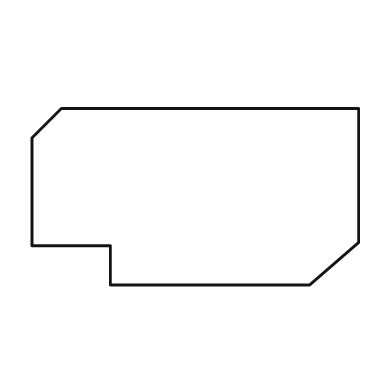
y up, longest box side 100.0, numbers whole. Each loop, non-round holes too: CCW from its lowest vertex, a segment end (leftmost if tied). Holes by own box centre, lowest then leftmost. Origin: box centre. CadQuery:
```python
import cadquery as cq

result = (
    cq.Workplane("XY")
    .moveTo(-26.0, -27.0)
    .lineTo(35.0, -27.0)
    .lineTo(50.0, -14.0)
    .lineTo(50.0, 27.0)
    .lineTo(-41.0, 27.0)
    .lineTo(-50.0, 18.0)
    .lineTo(-50.0, -15.0)
    .lineTo(-26.0, -15.0)
    .close()
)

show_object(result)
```